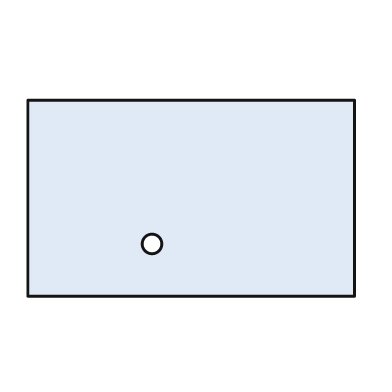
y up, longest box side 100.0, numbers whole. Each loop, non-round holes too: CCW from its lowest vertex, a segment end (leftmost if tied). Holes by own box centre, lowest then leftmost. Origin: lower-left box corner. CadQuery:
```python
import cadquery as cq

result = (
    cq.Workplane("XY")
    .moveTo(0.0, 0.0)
    .lineTo(100.0, 0.0)
    .lineTo(100.0, 60.0)
    .lineTo(0.0, 60.0)
    .close()
    .moveTo(38.0, 16.0)
    .circle(3.0)
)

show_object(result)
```